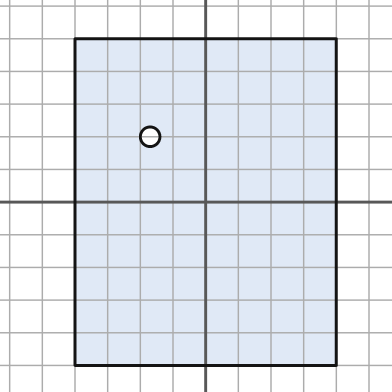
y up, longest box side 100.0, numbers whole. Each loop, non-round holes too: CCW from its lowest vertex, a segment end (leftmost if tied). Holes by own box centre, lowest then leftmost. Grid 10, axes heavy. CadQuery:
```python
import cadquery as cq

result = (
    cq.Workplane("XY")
    .moveTo(-40.0, -50.0)
    .lineTo(40.0, -50.0)
    .lineTo(40.0, 50.0)
    .lineTo(-40.0, 50.0)
    .close()
    .moveTo(-17.0, 20.0)
    .circle(3.0)
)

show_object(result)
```